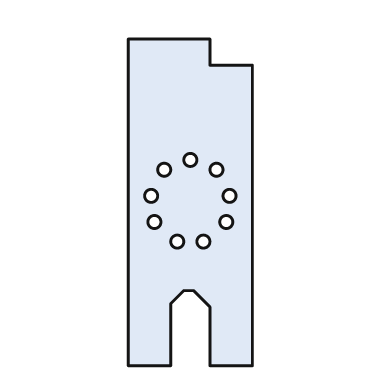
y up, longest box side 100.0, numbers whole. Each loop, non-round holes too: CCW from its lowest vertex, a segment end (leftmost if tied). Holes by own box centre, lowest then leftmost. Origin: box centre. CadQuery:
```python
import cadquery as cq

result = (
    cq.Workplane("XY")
    .moveTo(-19.0, -50.0)
    .lineTo(-6.0, -50.0)
    .lineTo(-6.0, -31.0)
    .lineTo(-2.0, -27.0)
    .lineTo(1.0, -27.0)
    .lineTo(6.0, -32.0)
    .lineTo(6.0, -50.0)
    .lineTo(19.0, -50.0)
    .lineTo(19.0, 42.0)
    .lineTo(6.0, 42.0)
    .lineTo(6.0, 50.0)
    .lineTo(-19.0, 50.0)
    .close()
    .moveTo(-4.0, -12.0)
    .circle(2.0)
    .moveTo(4.0, -12.0)
    .circle(2.0)
    .moveTo(-11.0, -6.0)
    .circle(2.0)
    .moveTo(11.0, -6.0)
    .circle(2.0)
    .moveTo(-12.0, 2.0)
    .circle(2.0)
    .moveTo(12.0, 2.0)
    .circle(2.0)
    .moveTo(-8.0, 10.0)
    .circle(2.0)
    .moveTo(8.0, 10.0)
    .circle(2.0)
    .moveTo(0.0, 13.0)
    .circle(2.0)
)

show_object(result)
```